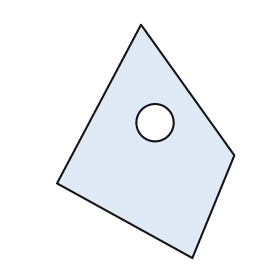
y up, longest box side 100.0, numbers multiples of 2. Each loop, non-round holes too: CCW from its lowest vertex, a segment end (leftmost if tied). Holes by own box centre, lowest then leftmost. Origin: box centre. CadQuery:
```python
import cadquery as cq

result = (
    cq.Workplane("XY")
    .moveTo(20.0, -50.0)
    .lineTo(38.0, -6.0)
    .lineTo(-2.0, 50.0)
    .lineTo(-38.0, -18.0)
    .close()
    .moveTo(4.0, 8.0)
    .circle(8.0)
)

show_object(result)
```